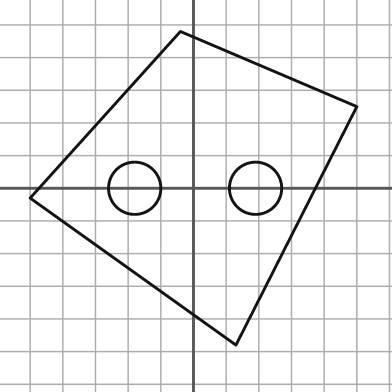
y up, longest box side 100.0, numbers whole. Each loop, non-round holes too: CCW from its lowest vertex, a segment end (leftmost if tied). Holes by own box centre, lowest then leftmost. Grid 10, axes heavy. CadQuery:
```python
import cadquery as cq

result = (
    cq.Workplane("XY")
    .moveTo(13.0, -48.0)
    .lineTo(50.0, 25.0)
    .lineTo(-4.0, 48.0)
    .lineTo(-50.0, -3.0)
    .close()
    .moveTo(-18.0, 0.0)
    .circle(8.0)
    .moveTo(19.0, 0.0)
    .circle(8.0)
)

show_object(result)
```